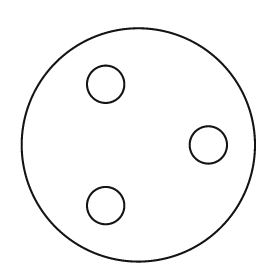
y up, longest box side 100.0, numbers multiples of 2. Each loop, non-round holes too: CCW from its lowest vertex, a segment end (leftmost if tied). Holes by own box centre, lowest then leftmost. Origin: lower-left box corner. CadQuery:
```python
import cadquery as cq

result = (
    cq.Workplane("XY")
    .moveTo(50.0, 50.0)
    .circle(50.0)
    .moveTo(36.0, 24.0)
    .circle(8.0)
    .moveTo(80.0, 50.0)
    .circle(8.0)
    .moveTo(36.0, 76.0)
    .circle(8.0)
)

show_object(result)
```